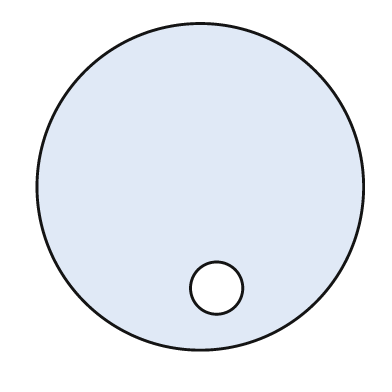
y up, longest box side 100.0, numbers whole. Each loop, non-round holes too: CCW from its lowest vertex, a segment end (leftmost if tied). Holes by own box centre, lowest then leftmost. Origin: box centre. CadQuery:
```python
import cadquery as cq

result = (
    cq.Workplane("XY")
    .moveTo(0.0, 0.0)
    .circle(50.0)
    .moveTo(5.0, -31.0)
    .circle(8.0)
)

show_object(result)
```